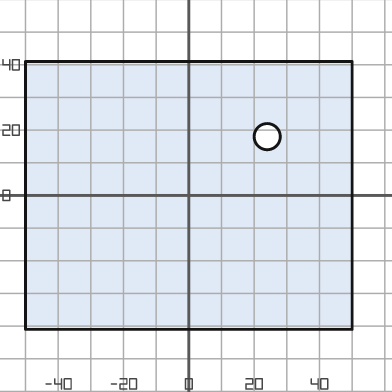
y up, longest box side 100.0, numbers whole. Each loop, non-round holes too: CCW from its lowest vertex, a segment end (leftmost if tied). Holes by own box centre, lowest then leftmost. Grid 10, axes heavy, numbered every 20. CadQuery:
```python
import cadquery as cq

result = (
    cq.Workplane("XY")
    .moveTo(-50.0, -41.0)
    .lineTo(50.0, -41.0)
    .lineTo(50.0, 41.0)
    .lineTo(-50.0, 41.0)
    .close()
    .moveTo(24.0, 18.0)
    .circle(4.0)
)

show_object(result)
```